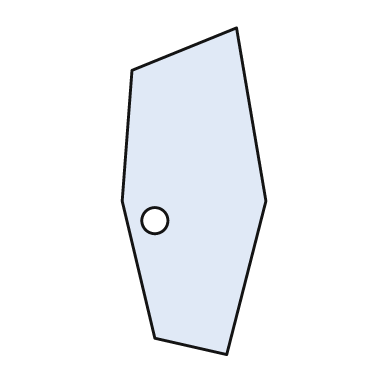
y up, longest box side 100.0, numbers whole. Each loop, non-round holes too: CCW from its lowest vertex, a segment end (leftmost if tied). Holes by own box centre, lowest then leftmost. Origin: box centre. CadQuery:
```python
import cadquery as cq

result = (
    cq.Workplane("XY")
    .moveTo(10.0, -50.0)
    .lineTo(22.0, -3.0)
    .lineTo(13.0, 50.0)
    .lineTo(-19.0, 37.0)
    .lineTo(-22.0, -3.0)
    .lineTo(-12.0, -45.0)
    .close()
    .moveTo(-12.0, -9.0)
    .circle(4.0)
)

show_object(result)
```